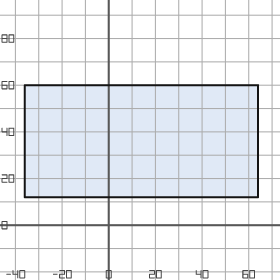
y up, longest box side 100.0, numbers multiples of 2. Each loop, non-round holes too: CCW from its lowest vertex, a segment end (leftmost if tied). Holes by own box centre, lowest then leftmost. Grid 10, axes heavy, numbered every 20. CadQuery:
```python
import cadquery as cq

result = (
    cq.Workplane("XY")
    .moveTo(-36.0, 12.0)
    .lineTo(64.0, 12.0)
    .lineTo(64.0, 60.0)
    .lineTo(-36.0, 60.0)
    .close()
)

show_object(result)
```